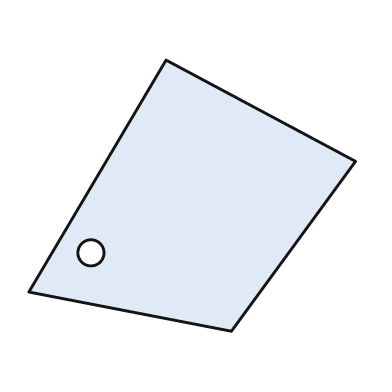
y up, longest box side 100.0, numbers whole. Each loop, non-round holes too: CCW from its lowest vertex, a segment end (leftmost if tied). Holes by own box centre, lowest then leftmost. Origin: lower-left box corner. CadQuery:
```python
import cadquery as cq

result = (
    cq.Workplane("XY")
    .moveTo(62.0, 0.0)
    .lineTo(100.0, 52.0)
    .lineTo(42.0, 83.0)
    .lineTo(0.0, 12.0)
    .close()
    .moveTo(19.0, 24.0)
    .circle(4.0)
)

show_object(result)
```